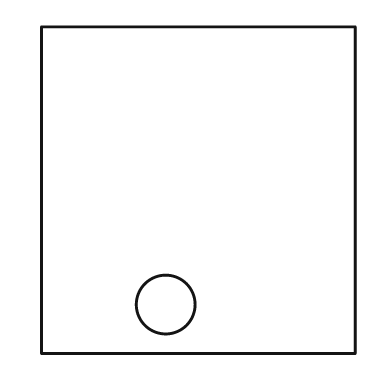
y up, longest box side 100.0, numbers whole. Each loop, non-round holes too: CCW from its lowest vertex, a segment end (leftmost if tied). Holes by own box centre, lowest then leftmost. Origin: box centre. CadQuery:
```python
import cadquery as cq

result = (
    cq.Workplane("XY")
    .moveTo(-48.0, -50.0)
    .lineTo(48.0, -50.0)
    .lineTo(48.0, 50.0)
    .lineTo(-48.0, 50.0)
    .close()
    .moveTo(-10.0, -35.0)
    .circle(9.0)
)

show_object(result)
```